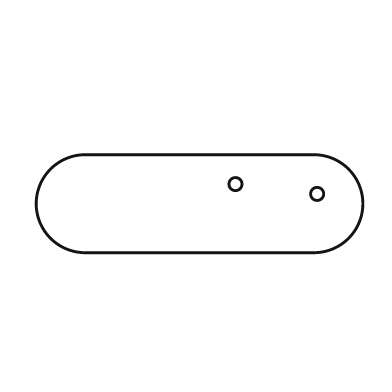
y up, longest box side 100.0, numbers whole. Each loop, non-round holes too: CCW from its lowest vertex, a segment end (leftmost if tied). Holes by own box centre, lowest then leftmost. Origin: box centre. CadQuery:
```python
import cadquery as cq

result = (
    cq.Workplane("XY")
    .moveTo(-35.0, -15.0)
    .lineTo(35.0, -15.0)
    .threePointArc((50.0, 0.0), (35.0, 15.0))
    .lineTo(-35.0, 15.0)
    .threePointArc((-50.0, 0.0), (-35.0, -15.0))
    .close()
    .moveTo(36.0, 3.0)
    .circle(2.0)
    .moveTo(11.0, 6.0)
    .circle(2.0)
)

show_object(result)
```